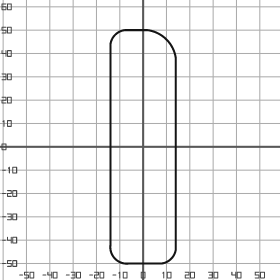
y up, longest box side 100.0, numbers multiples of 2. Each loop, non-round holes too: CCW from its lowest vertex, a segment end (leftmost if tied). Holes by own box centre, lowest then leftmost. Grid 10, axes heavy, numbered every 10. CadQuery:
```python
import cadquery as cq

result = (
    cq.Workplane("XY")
    .moveTo(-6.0, -50.0)
    .lineTo(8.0, -50.0)
    .threePointArc((12.0, -48.0), (14.0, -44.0))
    .lineTo(14.0, 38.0)
    .threePointArc((10.0, 46.0), (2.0, 50.0))
    .lineTo(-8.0, 50.0)
    .threePointArc((-12.0, 48.0), (-14.0, 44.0))
    .lineTo(-14.0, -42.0)
    .threePointArc((-12.0, -48.0), (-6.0, -50.0))
    .close()
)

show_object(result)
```